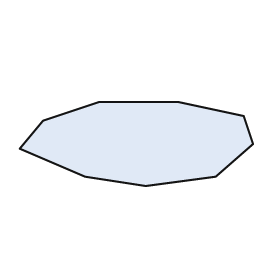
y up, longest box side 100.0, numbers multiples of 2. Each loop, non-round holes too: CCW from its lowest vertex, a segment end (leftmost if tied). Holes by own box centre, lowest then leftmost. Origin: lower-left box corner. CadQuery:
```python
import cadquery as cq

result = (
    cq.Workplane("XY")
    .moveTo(54.0, 0.0)
    .lineTo(84.0, 4.0)
    .lineTo(100.0, 18.0)
    .lineTo(96.0, 30.0)
    .lineTo(68.0, 36.0)
    .lineTo(34.0, 36.0)
    .lineTo(10.0, 28.0)
    .lineTo(0.0, 16.0)
    .lineTo(28.0, 4.0)
    .close()
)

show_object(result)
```